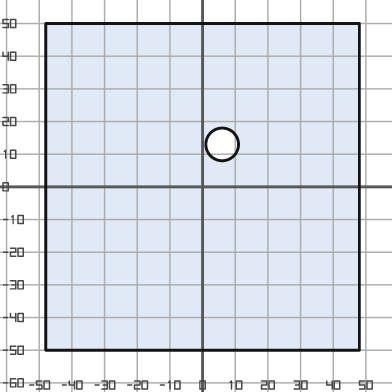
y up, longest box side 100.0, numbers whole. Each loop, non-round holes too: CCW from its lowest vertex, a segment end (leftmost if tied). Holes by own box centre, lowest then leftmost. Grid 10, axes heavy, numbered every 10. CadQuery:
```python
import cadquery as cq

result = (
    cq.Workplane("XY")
    .moveTo(-48.0, -50.0)
    .lineTo(48.0, -50.0)
    .lineTo(48.0, 50.0)
    .lineTo(-48.0, 50.0)
    .close()
    .moveTo(6.0, 13.0)
    .circle(5.0)
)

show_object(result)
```